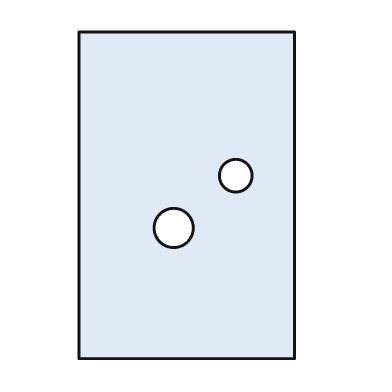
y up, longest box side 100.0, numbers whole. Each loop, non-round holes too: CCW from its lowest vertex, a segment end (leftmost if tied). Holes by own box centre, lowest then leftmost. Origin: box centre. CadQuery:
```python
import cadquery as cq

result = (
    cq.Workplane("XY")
    .moveTo(-33.0, -50.0)
    .lineTo(33.0, -50.0)
    .lineTo(33.0, 50.0)
    .lineTo(-33.0, 50.0)
    .close()
    .moveTo(-4.0, -10.0)
    .circle(6.0)
    .moveTo(15.0, 6.0)
    .circle(5.0)
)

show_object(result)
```